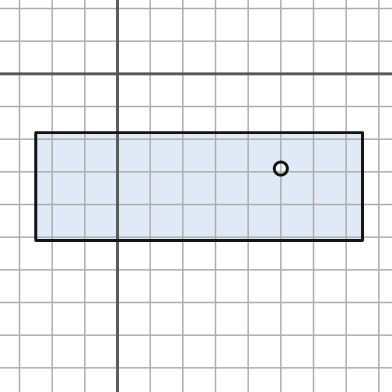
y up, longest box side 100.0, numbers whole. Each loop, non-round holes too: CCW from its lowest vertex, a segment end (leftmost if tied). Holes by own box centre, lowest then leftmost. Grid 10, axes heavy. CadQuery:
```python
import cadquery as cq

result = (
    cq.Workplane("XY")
    .moveTo(-25.0, -51.0)
    .lineTo(75.0, -51.0)
    .lineTo(75.0, -18.0)
    .lineTo(-25.0, -18.0)
    .close()
    .moveTo(50.0, -29.0)
    .circle(2.0)
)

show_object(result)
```